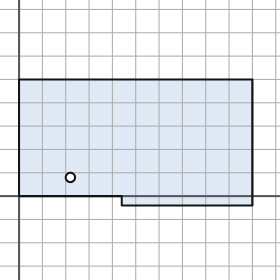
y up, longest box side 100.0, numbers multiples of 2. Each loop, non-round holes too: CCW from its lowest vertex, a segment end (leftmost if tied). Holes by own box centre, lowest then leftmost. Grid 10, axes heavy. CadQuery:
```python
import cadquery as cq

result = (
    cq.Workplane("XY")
    .moveTo(44.0, -4.0)
    .lineTo(100.0, -4.0)
    .lineTo(100.0, 50.0)
    .lineTo(0.0, 50.0)
    .lineTo(0.0, 0.0)
    .lineTo(44.0, 0.0)
    .close()
    .moveTo(22.0, 8.0)
    .circle(2.0)
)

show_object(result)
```